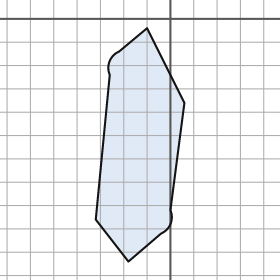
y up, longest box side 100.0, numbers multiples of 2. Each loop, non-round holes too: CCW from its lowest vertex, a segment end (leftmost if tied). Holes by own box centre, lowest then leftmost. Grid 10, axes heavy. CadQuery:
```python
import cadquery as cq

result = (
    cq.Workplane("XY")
    .moveTo(-18.0, -104.0)
    .lineTo(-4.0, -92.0)
    .threePointArc((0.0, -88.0), (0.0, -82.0))
    .lineTo(6.0, -36.0)
    .lineTo(-10.0, -4.0)
    .lineTo(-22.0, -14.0)
    .threePointArc((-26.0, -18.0), (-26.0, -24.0))
    .lineTo(-32.0, -86.0)
    .close()
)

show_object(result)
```